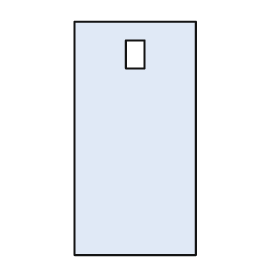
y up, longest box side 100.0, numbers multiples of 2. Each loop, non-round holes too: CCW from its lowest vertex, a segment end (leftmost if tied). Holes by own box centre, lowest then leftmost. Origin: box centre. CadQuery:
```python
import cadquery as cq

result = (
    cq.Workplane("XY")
    .moveTo(-26.0, -50.0)
    .lineTo(26.0, -50.0)
    .lineTo(26.0, 50.0)
    .lineTo(-26.0, 50.0)
    .close()
    .moveTo(-4.0, 30.0)
    .lineTo(4.0, 30.0)
    .lineTo(4.0, 42.0)
    .lineTo(-4.0, 42.0)
    .close()
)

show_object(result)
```